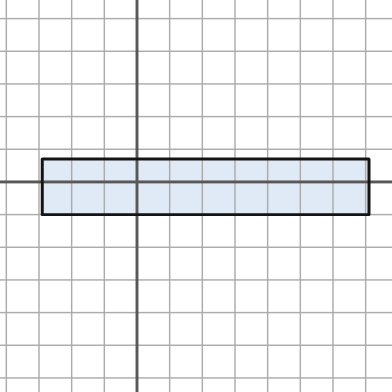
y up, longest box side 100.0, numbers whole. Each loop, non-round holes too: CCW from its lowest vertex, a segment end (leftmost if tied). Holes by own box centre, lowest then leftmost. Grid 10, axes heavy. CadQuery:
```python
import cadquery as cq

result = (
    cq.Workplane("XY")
    .moveTo(-29.0, -10.0)
    .lineTo(71.0, -10.0)
    .lineTo(71.0, 7.0)
    .lineTo(-29.0, 7.0)
    .close()
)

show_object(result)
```